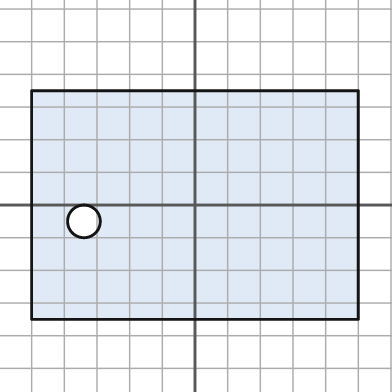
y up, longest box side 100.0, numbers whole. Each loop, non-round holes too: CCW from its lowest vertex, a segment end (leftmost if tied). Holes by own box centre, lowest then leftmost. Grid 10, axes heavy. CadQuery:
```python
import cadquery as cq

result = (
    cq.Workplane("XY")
    .moveTo(-50.0, -35.0)
    .lineTo(50.0, -35.0)
    .lineTo(50.0, 35.0)
    .lineTo(-50.0, 35.0)
    .close()
    .moveTo(-34.0, -5.0)
    .circle(5.0)
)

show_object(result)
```